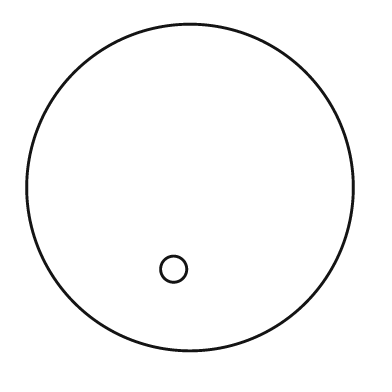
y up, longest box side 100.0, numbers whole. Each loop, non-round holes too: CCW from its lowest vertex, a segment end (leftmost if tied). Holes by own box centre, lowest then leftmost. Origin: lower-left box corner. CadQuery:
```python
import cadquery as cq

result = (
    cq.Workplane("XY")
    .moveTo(50.0, 50.0)
    .circle(50.0)
    .moveTo(45.0, 25.0)
    .circle(4.0)
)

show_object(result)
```